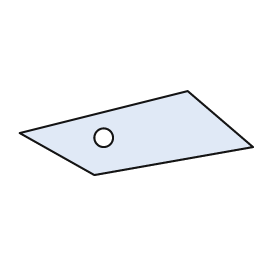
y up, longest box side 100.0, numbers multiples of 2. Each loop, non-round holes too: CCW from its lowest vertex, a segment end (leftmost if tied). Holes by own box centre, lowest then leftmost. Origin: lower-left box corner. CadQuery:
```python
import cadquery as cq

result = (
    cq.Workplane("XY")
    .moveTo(32.0, 0.0)
    .lineTo(100.0, 12.0)
    .lineTo(72.0, 36.0)
    .lineTo(0.0, 18.0)
    .close()
    .moveTo(36.0, 16.0)
    .circle(4.0)
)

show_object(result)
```